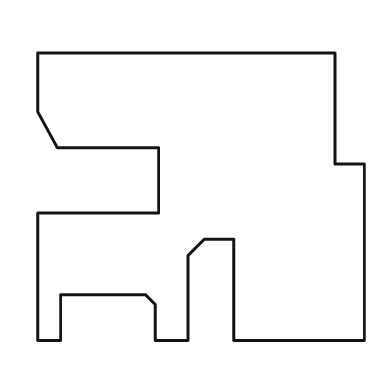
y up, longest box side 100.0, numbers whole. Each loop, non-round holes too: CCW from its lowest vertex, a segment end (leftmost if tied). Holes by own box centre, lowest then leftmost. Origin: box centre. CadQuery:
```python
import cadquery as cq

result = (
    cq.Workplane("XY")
    .moveTo(-50.0, -44.0)
    .lineTo(-43.0, -44.0)
    .lineTo(-43.0, -30.0)
    .lineTo(-17.0, -30.0)
    .lineTo(-14.0, -33.0)
    .lineTo(-14.0, -44.0)
    .lineTo(-4.0, -44.0)
    .lineTo(-4.0, -18.0)
    .lineTo(1.0, -13.0)
    .lineTo(10.0, -13.0)
    .lineTo(10.0, -44.0)
    .lineTo(50.0, -44.0)
    .lineTo(50.0, 10.0)
    .lineTo(41.0, 10.0)
    .lineTo(41.0, 44.0)
    .lineTo(-50.0, 44.0)
    .lineTo(-50.0, 26.0)
    .lineTo(-44.0, 15.0)
    .lineTo(-13.0, 15.0)
    .lineTo(-13.0, -5.0)
    .lineTo(-50.0, -5.0)
    .close()
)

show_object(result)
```